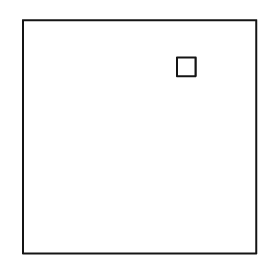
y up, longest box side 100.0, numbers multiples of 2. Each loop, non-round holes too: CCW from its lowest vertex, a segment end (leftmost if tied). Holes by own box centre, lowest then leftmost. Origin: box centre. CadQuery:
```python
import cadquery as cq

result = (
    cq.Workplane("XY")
    .moveTo(-50.0, -50.0)
    .lineTo(50.0, -50.0)
    .lineTo(50.0, 50.0)
    .lineTo(-50.0, 50.0)
    .close()
    .moveTo(16.0, 26.0)
    .lineTo(24.0, 26.0)
    .lineTo(24.0, 34.0)
    .lineTo(16.0, 34.0)
    .close()
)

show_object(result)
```